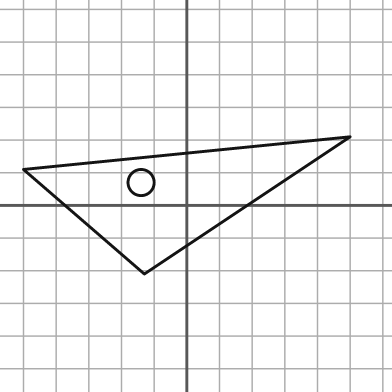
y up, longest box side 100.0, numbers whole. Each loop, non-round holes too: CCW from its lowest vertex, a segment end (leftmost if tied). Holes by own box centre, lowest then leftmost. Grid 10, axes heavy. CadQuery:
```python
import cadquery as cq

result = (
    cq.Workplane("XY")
    .moveTo(-13.0, -21.0)
    .lineTo(50.0, 21.0)
    .lineTo(-50.0, 11.0)
    .close()
    .moveTo(-14.0, 7.0)
    .circle(4.0)
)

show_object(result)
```